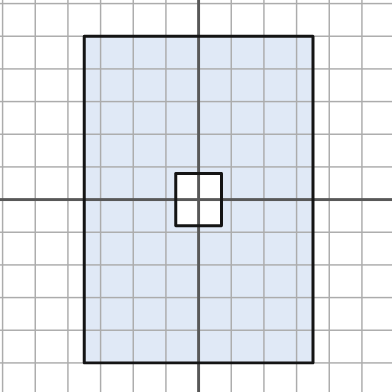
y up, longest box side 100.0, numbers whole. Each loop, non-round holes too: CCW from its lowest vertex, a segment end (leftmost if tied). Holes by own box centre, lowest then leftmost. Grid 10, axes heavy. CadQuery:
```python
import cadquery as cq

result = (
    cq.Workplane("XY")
    .moveTo(-35.0, -50.0)
    .lineTo(35.0, -50.0)
    .lineTo(35.0, 50.0)
    .lineTo(-35.0, 50.0)
    .close()
    .moveTo(-7.0, -8.0)
    .lineTo(7.0, -8.0)
    .lineTo(7.0, 8.0)
    .lineTo(-7.0, 8.0)
    .close()
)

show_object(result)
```